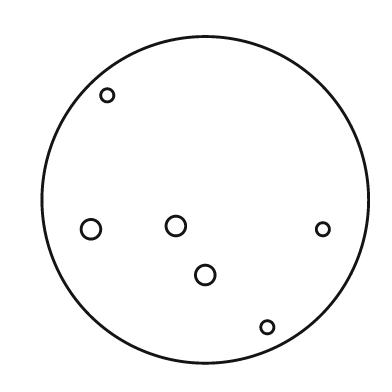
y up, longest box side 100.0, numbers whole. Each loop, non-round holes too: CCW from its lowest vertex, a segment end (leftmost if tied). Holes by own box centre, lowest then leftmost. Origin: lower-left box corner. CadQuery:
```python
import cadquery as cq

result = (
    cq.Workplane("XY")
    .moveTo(50.0, 50.0)
    .circle(50.0)
    .moveTo(69.0, 11.0)
    .circle(2.0)
    .moveTo(50.0, 27.0)
    .circle(3.0)
    .moveTo(15.0, 41.0)
    .circle(3.0)
    .moveTo(86.0, 41.0)
    .circle(2.0)
    .moveTo(41.0, 42.0)
    .circle(3.0)
    .moveTo(20.0, 82.0)
    .circle(2.0)
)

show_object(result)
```